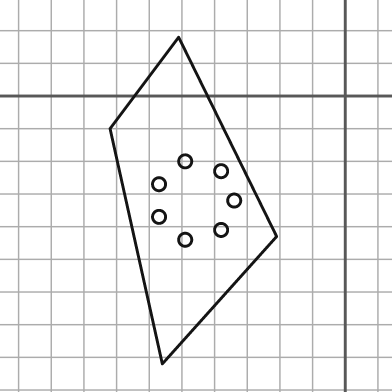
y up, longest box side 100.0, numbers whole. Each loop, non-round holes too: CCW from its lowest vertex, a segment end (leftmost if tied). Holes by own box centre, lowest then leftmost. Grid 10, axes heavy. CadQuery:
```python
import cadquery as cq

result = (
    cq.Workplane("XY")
    .moveTo(-56.0, -82.0)
    .lineTo(-21.0, -43.0)
    .lineTo(-51.0, 18.0)
    .lineTo(-72.0, -10.0)
    .close()
    .moveTo(-49.0, -44.0)
    .circle(2.0)
    .moveTo(-38.0, -41.0)
    .circle(2.0)
    .moveTo(-57.0, -37.0)
    .circle(2.0)
    .moveTo(-34.0, -32.0)
    .circle(2.0)
    .moveTo(-57.0, -27.0)
    .circle(2.0)
    .moveTo(-38.0, -23.0)
    .circle(2.0)
    .moveTo(-49.0, -20.0)
    .circle(2.0)
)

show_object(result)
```